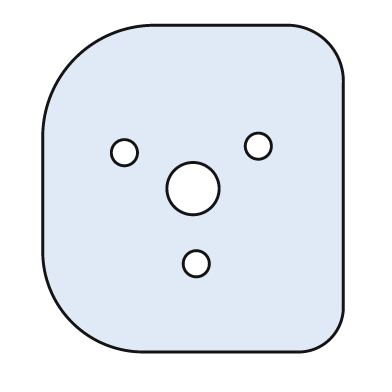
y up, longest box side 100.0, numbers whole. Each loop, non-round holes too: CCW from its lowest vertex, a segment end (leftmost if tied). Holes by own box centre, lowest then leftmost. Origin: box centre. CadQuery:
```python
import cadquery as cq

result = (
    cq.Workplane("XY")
    .moveTo(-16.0, -50.0)
    .lineTo(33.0, -50.0)
    .threePointArc((42.0, -46.0), (46.0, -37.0))
    .lineTo(46.0, 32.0)
    .threePointArc((41.0, 45.0), (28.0, 50.0))
    .lineTo(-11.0, 50.0)
    .threePointArc((-36.0, 40.0), (-46.0, 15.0))
    .lineTo(-46.0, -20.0)
    .threePointArc((-37.0, -41.0), (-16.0, -50.0))
    .close()
    .moveTo(1.0, -23.0)
    .circle(4.0)
    .moveTo(0.0, 0.0)
    .circle(8.0)
    .moveTo(-21.0, 11.0)
    .circle(4.0)
    .moveTo(20.0, 13.0)
    .circle(4.0)
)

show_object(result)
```